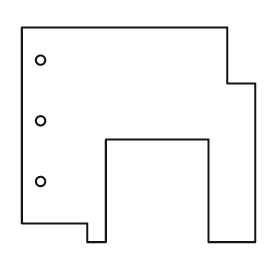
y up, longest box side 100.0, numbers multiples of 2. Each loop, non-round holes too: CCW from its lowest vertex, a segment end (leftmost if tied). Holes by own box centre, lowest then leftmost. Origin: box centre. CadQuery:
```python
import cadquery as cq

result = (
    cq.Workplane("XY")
    .moveTo(-22.0, -46.0)
    .lineTo(-14.0, -46.0)
    .lineTo(-14.0, -2.0)
    .lineTo(30.0, -2.0)
    .lineTo(30.0, -46.0)
    .lineTo(50.0, -46.0)
    .lineTo(50.0, 22.0)
    .lineTo(38.0, 22.0)
    .lineTo(38.0, 46.0)
    .lineTo(-50.0, 46.0)
    .lineTo(-50.0, -38.0)
    .lineTo(-22.0, -38.0)
    .close()
    .moveTo(-42.0, -20.0)
    .circle(2.0)
    .moveTo(-42.0, 6.0)
    .circle(2.0)
    .moveTo(-42.0, 32.0)
    .circle(2.0)
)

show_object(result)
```